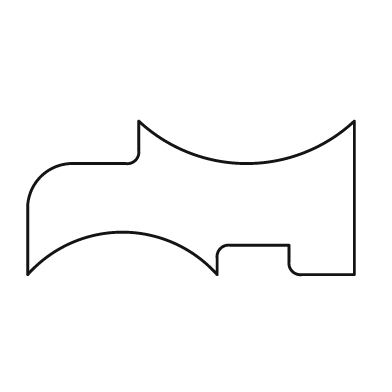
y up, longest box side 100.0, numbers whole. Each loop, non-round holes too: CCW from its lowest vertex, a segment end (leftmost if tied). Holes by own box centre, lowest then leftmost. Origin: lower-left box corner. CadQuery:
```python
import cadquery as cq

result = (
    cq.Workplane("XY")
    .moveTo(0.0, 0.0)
    .threePointArc((29.0, 13.0), (58.0, 0.0))
    .lineTo(58.0, 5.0)
    .threePointArc((59.0, 8.0), (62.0, 9.0))
    .lineTo(80.0, 9.0)
    .lineTo(80.0, 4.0)
    .threePointArc((81.0, 1.0), (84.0, 0.0))
    .lineTo(100.0, 0.0)
    .lineTo(100.0, 47.0)
    .threePointArc((67.0, 34.0), (34.0, 47.0))
    .lineTo(34.0, 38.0)
    .threePointArc((33.0, 35.0), (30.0, 34.0))
    .lineTo(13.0, 34.0)
    .threePointArc((4.0, 30.0), (0.0, 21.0))
    .close()
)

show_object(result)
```